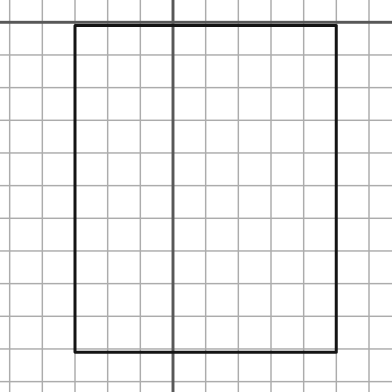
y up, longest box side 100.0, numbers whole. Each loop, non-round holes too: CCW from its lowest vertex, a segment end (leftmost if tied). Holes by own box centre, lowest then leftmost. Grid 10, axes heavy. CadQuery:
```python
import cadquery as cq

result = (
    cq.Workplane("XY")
    .moveTo(-30.0, -101.0)
    .lineTo(50.0, -101.0)
    .lineTo(50.0, -1.0)
    .lineTo(-30.0, -1.0)
    .close()
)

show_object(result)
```